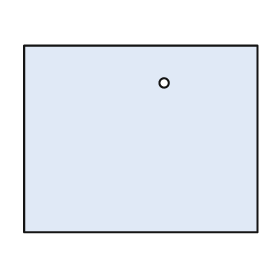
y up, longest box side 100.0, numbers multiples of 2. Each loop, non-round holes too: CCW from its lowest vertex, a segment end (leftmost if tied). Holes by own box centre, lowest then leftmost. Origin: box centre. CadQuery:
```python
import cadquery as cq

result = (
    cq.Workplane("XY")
    .moveTo(-50.0, -40.0)
    .lineTo(50.0, -40.0)
    .lineTo(50.0, 40.0)
    .lineTo(-50.0, 40.0)
    .close()
    .moveTo(10.0, 24.0)
    .circle(2.0)
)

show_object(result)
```